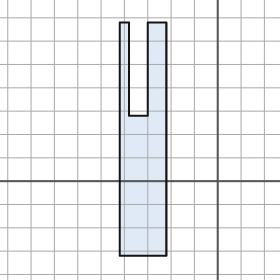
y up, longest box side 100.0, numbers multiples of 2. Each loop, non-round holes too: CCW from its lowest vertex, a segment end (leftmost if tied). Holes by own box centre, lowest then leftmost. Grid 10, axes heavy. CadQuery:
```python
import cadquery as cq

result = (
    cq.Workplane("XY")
    .moveTo(-42.0, -32.0)
    .lineTo(-22.0, -32.0)
    .lineTo(-22.0, 68.0)
    .lineTo(-30.0, 68.0)
    .lineTo(-30.0, 28.0)
    .lineTo(-38.0, 28.0)
    .lineTo(-38.0, 68.0)
    .lineTo(-42.0, 68.0)
    .close()
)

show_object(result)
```